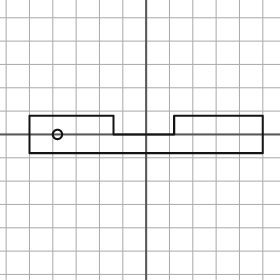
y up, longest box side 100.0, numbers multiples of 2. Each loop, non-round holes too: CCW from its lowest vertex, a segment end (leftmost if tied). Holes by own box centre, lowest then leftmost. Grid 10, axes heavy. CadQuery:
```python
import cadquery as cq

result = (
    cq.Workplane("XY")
    .moveTo(-50.0, -8.0)
    .lineTo(50.0, -8.0)
    .lineTo(50.0, 8.0)
    .lineTo(12.0, 8.0)
    .lineTo(12.0, 0.0)
    .lineTo(-14.0, 0.0)
    .lineTo(-14.0, 8.0)
    .lineTo(-50.0, 8.0)
    .close()
    .moveTo(-38.0, 0.0)
    .circle(2.0)
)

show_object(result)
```